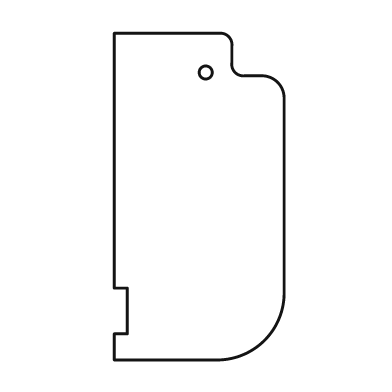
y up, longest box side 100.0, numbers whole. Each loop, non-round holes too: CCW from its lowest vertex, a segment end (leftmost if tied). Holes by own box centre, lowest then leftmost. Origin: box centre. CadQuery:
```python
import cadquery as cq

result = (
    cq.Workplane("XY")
    .moveTo(-26.0, -50.0)
    .lineTo(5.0, -50.0)
    .threePointArc((20.0, -44.0), (26.0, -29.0))
    .lineTo(26.0, 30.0)
    .threePointArc((24.0, 35.0), (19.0, 37.0))
    .lineTo(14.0, 37.0)
    .threePointArc((11.0, 38.0), (10.0, 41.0))
    .lineTo(10.0, 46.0)
    .threePointArc((9.0, 49.0), (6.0, 50.0))
    .lineTo(-26.0, 50.0)
    .lineTo(-26.0, -28.0)
    .lineTo(-22.0, -28.0)
    .lineTo(-22.0, -42.0)
    .lineTo(-26.0, -42.0)
    .close()
    .moveTo(2.0, 38.0)
    .circle(2.0)
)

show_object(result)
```